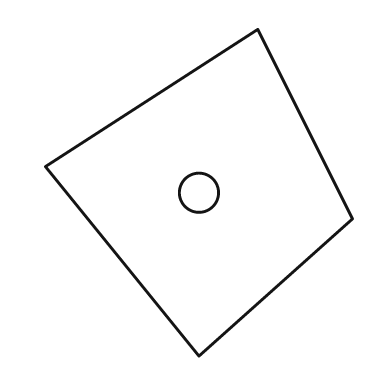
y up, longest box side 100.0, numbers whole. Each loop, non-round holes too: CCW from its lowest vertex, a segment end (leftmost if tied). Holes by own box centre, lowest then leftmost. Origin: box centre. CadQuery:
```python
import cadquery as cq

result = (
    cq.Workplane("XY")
    .moveTo(0.0, -50.0)
    .lineTo(47.0, -8.0)
    .lineTo(18.0, 50.0)
    .lineTo(-47.0, 8.0)
    .close()
    .moveTo(0.0, 0.0)
    .circle(6.0)
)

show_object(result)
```